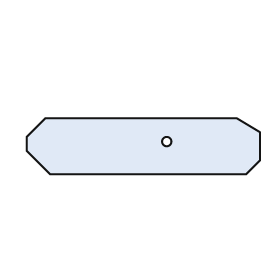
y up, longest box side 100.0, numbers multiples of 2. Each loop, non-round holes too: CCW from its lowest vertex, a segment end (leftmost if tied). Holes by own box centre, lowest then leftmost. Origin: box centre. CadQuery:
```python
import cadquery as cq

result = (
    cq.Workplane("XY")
    .moveTo(-40.0, -12.0)
    .lineTo(44.0, -12.0)
    .lineTo(50.0, -6.0)
    .lineTo(50.0, 6.0)
    .lineTo(40.0, 12.0)
    .lineTo(-42.0, 12.0)
    .lineTo(-50.0, 4.0)
    .lineTo(-50.0, -2.0)
    .close()
    .moveTo(10.0, 2.0)
    .circle(2.0)
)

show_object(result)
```